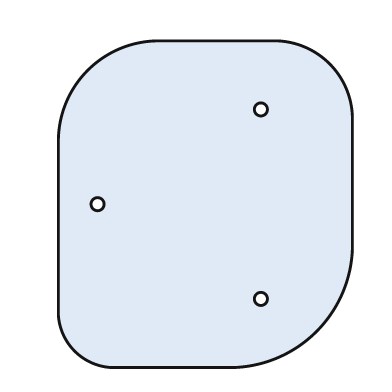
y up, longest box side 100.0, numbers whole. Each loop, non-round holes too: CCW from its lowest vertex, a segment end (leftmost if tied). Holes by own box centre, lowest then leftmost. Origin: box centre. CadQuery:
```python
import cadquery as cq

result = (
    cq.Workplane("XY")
    .moveTo(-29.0, -50.0)
    .lineTo(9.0, -50.0)
    .threePointArc((34.0, -39.0), (45.0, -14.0))
    .lineTo(45.0, 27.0)
    .threePointArc((38.0, 43.0), (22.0, 50.0))
    .lineTo(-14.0, 50.0)
    .threePointArc((-36.0, 41.0), (-45.0, 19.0))
    .lineTo(-45.0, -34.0)
    .threePointArc((-40.0, -45.0), (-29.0, -50.0))
    .close()
    .moveTo(17.0, -29.0)
    .circle(2.0)
    .moveTo(-33.0, 0.0)
    .circle(2.0)
    .moveTo(17.0, 29.0)
    .circle(2.0)
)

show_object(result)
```